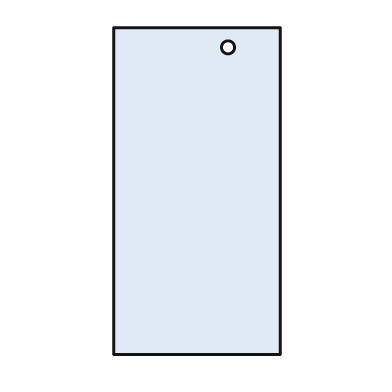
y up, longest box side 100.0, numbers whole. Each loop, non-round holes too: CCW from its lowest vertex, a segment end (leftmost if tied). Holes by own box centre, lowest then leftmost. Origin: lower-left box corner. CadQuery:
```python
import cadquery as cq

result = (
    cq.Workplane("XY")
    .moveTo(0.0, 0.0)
    .lineTo(51.0, 0.0)
    .lineTo(51.0, 100.0)
    .lineTo(0.0, 100.0)
    .close()
    .moveTo(35.0, 94.0)
    .circle(2.0)
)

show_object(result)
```